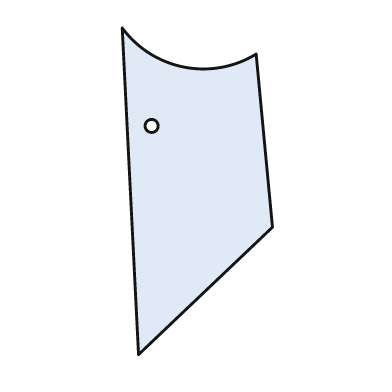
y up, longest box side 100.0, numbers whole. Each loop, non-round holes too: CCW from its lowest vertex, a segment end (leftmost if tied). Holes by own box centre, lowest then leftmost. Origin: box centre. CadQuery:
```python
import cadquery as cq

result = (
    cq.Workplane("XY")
    .moveTo(-18.0, -50.0)
    .lineTo(23.0, -11.0)
    .lineTo(18.0, 42.0)
    .threePointArc((-4.0, 38.0), (-23.0, 50.0))
    .close()
    .moveTo(-14.0, 20.0)
    .circle(2.0)
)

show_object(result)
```